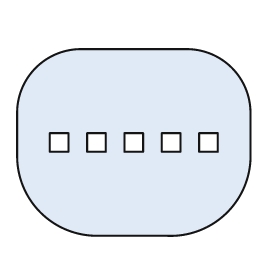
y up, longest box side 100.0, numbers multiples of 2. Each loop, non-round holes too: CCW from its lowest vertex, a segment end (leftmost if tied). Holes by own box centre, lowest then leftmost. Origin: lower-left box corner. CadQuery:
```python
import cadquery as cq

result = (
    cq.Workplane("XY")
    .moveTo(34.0, 0.0)
    .lineTo(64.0, 0.0)
    .threePointArc((90.0, 10.0), (100.0, 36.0))
    .lineTo(100.0, 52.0)
    .threePointArc((92.0, 72.0), (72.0, 80.0))
    .lineTo(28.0, 80.0)
    .threePointArc((8.0, 72.0), (0.0, 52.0))
    .lineTo(0.0, 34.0)
    .threePointArc((10.0, 10.0), (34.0, 0.0))
    .close()
    .moveTo(14.0, 36.0)
    .lineTo(22.0, 36.0)
    .lineTo(22.0, 44.0)
    .lineTo(14.0, 44.0)
    .close()
    .moveTo(30.0, 36.0)
    .lineTo(38.0, 36.0)
    .lineTo(38.0, 44.0)
    .lineTo(30.0, 44.0)
    .close()
    .moveTo(46.0, 36.0)
    .lineTo(54.0, 36.0)
    .lineTo(54.0, 44.0)
    .lineTo(46.0, 44.0)
    .close()
    .moveTo(62.0, 36.0)
    .lineTo(70.0, 36.0)
    .lineTo(70.0, 44.0)
    .lineTo(62.0, 44.0)
    .close()
    .moveTo(78.0, 36.0)
    .lineTo(86.0, 36.0)
    .lineTo(86.0, 44.0)
    .lineTo(78.0, 44.0)
    .close()
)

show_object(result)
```